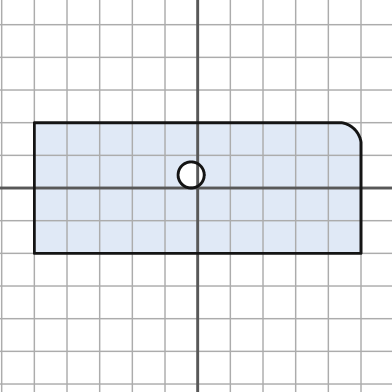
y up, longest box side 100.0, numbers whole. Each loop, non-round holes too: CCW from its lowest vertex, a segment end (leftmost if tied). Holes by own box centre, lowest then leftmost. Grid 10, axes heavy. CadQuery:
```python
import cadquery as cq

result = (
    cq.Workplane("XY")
    .moveTo(-50.0, -20.0)
    .lineTo(50.0, -20.0)
    .lineTo(50.0, 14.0)
    .threePointArc((48.0, 18.0), (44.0, 20.0))
    .lineTo(-50.0, 20.0)
    .close()
    .moveTo(-2.0, 4.0)
    .circle(4.0)
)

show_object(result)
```